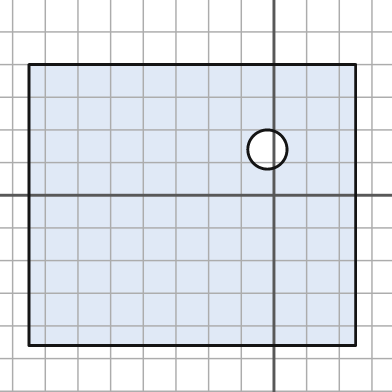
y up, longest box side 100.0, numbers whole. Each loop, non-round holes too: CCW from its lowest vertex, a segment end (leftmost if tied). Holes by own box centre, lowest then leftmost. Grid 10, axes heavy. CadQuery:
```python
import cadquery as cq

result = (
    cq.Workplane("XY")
    .moveTo(-75.0, -46.0)
    .lineTo(25.0, -46.0)
    .lineTo(25.0, 40.0)
    .lineTo(-75.0, 40.0)
    .close()
    .moveTo(-2.0, 14.0)
    .circle(6.0)
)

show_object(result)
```